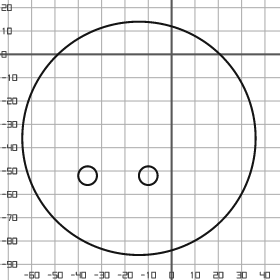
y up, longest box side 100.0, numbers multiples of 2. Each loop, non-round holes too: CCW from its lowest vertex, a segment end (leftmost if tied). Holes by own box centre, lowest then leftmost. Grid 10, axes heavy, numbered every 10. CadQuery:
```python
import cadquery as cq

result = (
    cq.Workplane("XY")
    .moveTo(-14.0, -36.0)
    .circle(50.0)
    .moveTo(-36.0, -52.0)
    .circle(4.0)
    .moveTo(-10.0, -52.0)
    .circle(4.0)
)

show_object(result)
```